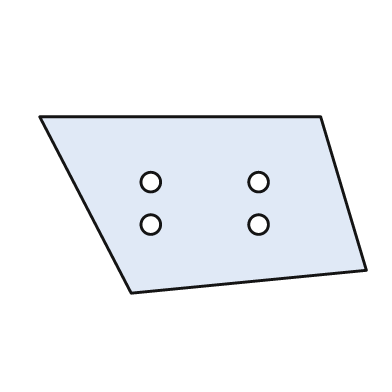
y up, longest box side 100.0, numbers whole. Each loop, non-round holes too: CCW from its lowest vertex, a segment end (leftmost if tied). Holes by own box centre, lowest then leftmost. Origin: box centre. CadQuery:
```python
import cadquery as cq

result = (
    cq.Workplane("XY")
    .moveTo(-22.0, -27.0)
    .lineTo(50.0, -20.0)
    .lineTo(36.0, 27.0)
    .lineTo(-50.0, 27.0)
    .close()
    .moveTo(-16.0, -6.0)
    .circle(3.0)
    .moveTo(17.0, -6.0)
    .circle(3.0)
    .moveTo(-16.0, 7.0)
    .circle(3.0)
    .moveTo(17.0, 7.0)
    .circle(3.0)
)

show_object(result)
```